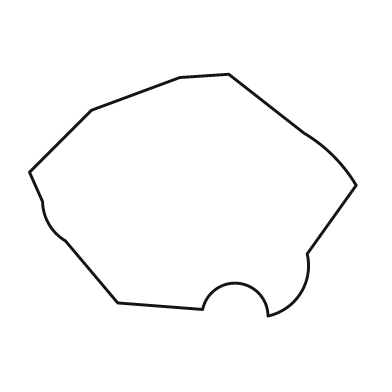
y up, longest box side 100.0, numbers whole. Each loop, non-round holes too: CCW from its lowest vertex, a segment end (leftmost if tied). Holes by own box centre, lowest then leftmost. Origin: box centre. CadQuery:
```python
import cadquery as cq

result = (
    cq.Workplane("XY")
    .moveTo(23.0, -37.0)
    .threePointArc((33.0, -30.0), (35.0, -18.0))
    .lineTo(50.0, 3.0)
    .threePointArc((43.0, 12.0), (34.0, 19.0))
    .lineTo(11.0, 37.0)
    .lineTo(-4.0, 36.0)
    .lineTo(-31.0, 26.0)
    .lineTo(-50.0, 7.0)
    .lineTo(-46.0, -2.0)
    .threePointArc((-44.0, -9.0), (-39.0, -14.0))
    .lineTo(-23.0, -33.0)
    .lineTo(3.0, -35.0)
    .threePointArc((14.0, -27.0), (23.0, -37.0))
    .close()
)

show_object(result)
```